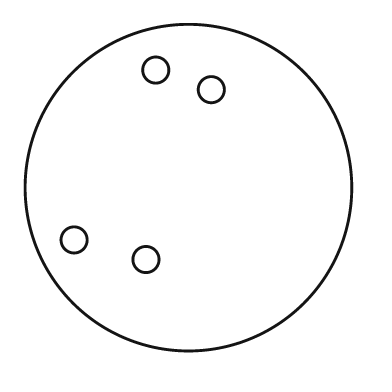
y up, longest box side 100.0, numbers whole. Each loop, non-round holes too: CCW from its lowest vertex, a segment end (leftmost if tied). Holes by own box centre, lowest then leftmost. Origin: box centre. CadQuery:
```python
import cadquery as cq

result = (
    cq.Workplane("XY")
    .moveTo(0.0, 0.0)
    .circle(50.0)
    .moveTo(-13.0, -22.0)
    .circle(4.0)
    .moveTo(-35.0, -16.0)
    .circle(4.0)
    .moveTo(7.0, 30.0)
    .circle(4.0)
    .moveTo(-10.0, 36.0)
    .circle(4.0)
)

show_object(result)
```